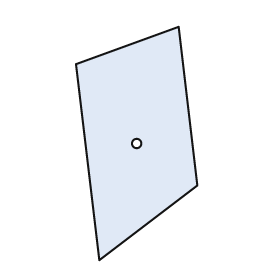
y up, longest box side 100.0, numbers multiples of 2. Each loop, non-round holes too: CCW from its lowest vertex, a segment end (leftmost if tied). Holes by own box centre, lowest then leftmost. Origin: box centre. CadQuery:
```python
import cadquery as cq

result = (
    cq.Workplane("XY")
    .moveTo(-16.0, -50.0)
    .lineTo(26.0, -18.0)
    .lineTo(18.0, 50.0)
    .lineTo(-26.0, 34.0)
    .close()
    .moveTo(0.0, 0.0)
    .circle(2.0)
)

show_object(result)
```